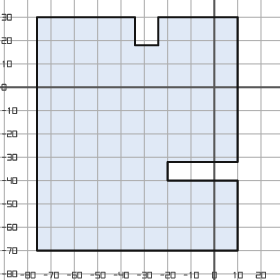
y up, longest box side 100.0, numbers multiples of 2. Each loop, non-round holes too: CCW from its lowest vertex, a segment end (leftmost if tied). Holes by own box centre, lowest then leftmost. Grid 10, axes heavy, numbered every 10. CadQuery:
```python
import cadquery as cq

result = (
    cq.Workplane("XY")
    .moveTo(-76.0, -70.0)
    .lineTo(10.0, -70.0)
    .lineTo(10.0, -40.0)
    .lineTo(-20.0, -40.0)
    .lineTo(-20.0, -32.0)
    .lineTo(10.0, -32.0)
    .lineTo(10.0, 30.0)
    .lineTo(-24.0, 30.0)
    .lineTo(-24.0, 18.0)
    .lineTo(-34.0, 18.0)
    .lineTo(-34.0, 30.0)
    .lineTo(-76.0, 30.0)
    .close()
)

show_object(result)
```